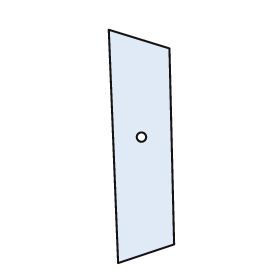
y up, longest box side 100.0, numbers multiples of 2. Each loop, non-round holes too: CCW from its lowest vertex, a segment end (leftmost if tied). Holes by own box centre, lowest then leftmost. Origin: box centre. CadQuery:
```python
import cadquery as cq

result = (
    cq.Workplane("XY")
    .moveTo(-10.0, -50.0)
    .lineTo(14.0, -42.0)
    .lineTo(12.0, 42.0)
    .lineTo(-14.0, 50.0)
    .close()
    .moveTo(0.0, 4.0)
    .circle(2.0)
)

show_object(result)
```